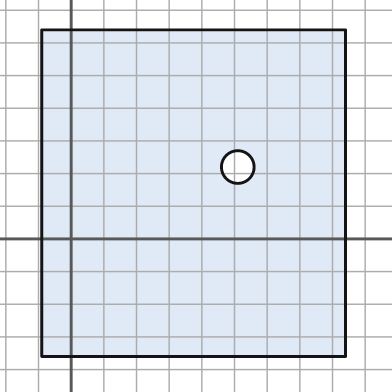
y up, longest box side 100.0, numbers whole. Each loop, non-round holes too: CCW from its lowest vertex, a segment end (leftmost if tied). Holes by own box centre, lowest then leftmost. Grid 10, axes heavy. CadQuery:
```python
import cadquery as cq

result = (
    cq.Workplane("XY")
    .moveTo(-9.0, -36.0)
    .lineTo(84.0, -36.0)
    .lineTo(84.0, 64.0)
    .lineTo(-9.0, 64.0)
    .close()
    .moveTo(51.0, 22.0)
    .circle(5.0)
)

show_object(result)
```